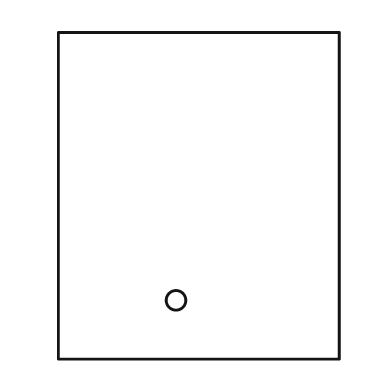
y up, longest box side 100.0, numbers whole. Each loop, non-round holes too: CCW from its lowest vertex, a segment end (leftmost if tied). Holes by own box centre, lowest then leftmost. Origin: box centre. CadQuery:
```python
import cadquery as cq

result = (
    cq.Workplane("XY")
    .moveTo(-43.0, -50.0)
    .lineTo(43.0, -50.0)
    .lineTo(43.0, 50.0)
    .lineTo(-43.0, 50.0)
    .close()
    .moveTo(-7.0, -32.0)
    .circle(3.0)
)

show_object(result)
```